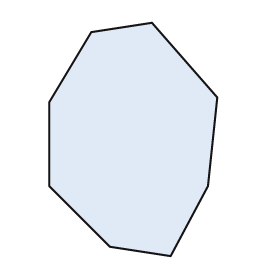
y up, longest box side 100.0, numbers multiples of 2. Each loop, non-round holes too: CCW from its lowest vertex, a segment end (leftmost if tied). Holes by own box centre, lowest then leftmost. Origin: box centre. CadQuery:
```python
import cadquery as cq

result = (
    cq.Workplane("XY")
    .moveTo(16.0, -50.0)
    .lineTo(32.0, -20.0)
    .lineTo(36.0, 18.0)
    .lineTo(8.0, 50.0)
    .lineTo(-18.0, 46.0)
    .lineTo(-36.0, 16.0)
    .lineTo(-36.0, -20.0)
    .lineTo(-10.0, -46.0)
    .close()
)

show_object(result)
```